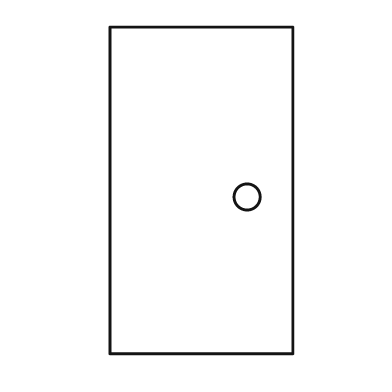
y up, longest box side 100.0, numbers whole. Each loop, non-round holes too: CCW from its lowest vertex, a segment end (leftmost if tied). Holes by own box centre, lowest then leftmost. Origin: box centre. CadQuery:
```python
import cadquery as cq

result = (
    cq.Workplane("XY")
    .moveTo(-28.0, -50.0)
    .lineTo(28.0, -50.0)
    .lineTo(28.0, 50.0)
    .lineTo(-28.0, 50.0)
    .close()
    .moveTo(14.0, -2.0)
    .circle(4.0)
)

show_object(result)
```